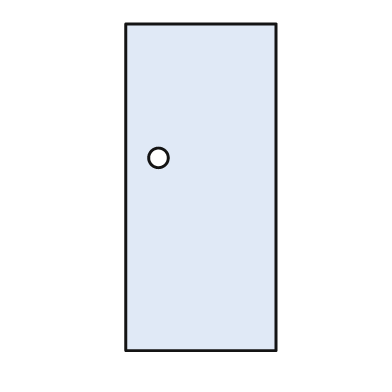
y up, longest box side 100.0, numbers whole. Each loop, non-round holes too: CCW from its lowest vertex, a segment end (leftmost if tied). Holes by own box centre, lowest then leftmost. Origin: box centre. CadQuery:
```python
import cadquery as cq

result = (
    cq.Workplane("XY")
    .moveTo(-23.0, -50.0)
    .lineTo(23.0, -50.0)
    .lineTo(23.0, 50.0)
    .lineTo(-23.0, 50.0)
    .close()
    .moveTo(-13.0, 9.0)
    .circle(3.0)
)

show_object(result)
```